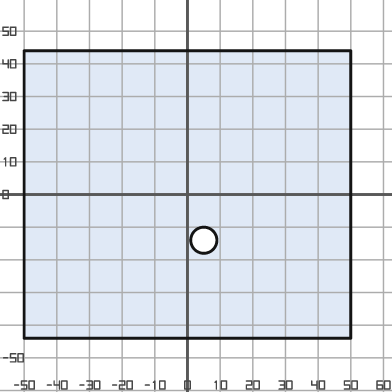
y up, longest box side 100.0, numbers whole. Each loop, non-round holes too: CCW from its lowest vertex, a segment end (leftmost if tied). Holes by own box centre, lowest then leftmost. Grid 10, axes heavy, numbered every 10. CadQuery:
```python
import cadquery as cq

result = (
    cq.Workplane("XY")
    .moveTo(-50.0, -44.0)
    .lineTo(50.0, -44.0)
    .lineTo(50.0, 44.0)
    .lineTo(-50.0, 44.0)
    .close()
    .moveTo(5.0, -14.0)
    .circle(4.0)
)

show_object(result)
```